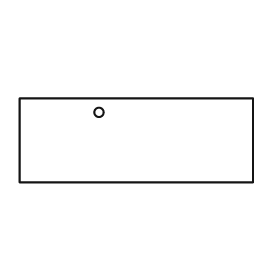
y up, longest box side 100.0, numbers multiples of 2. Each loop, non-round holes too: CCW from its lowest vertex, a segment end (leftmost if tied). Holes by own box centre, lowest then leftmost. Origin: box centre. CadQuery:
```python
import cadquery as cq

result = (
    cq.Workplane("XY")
    .moveTo(-50.0, -18.0)
    .lineTo(50.0, -18.0)
    .lineTo(50.0, 18.0)
    .lineTo(-50.0, 18.0)
    .close()
    .moveTo(-16.0, 12.0)
    .circle(2.0)
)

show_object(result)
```